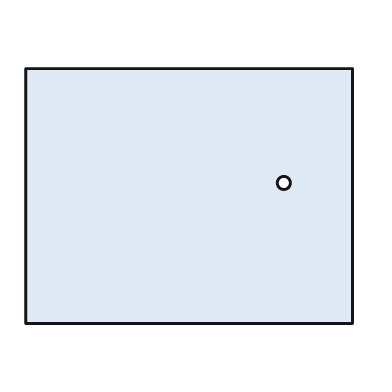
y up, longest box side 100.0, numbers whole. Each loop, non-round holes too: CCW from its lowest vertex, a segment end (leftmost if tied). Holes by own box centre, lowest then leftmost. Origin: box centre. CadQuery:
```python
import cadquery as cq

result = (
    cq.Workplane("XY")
    .moveTo(-50.0, -39.0)
    .lineTo(50.0, -39.0)
    .lineTo(50.0, 39.0)
    .lineTo(-50.0, 39.0)
    .close()
    .moveTo(29.0, 4.0)
    .circle(2.0)
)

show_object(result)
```